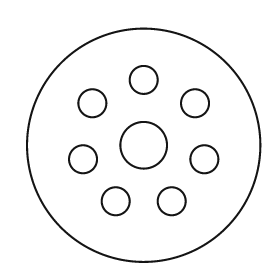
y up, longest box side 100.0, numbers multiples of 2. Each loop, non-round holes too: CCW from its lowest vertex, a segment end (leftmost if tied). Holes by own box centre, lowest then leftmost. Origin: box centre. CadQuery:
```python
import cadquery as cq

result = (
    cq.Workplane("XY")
    .moveTo(0.0, 0.0)
    .circle(50.0)
    .moveTo(-12.0, -24.0)
    .circle(6.0)
    .moveTo(12.0, -24.0)
    .circle(6.0)
    .moveTo(-26.0, -6.0)
    .circle(6.0)
    .moveTo(26.0, -6.0)
    .circle(6.0)
    .moveTo(0.0, 0.0)
    .circle(10.0)
    .moveTo(-22.0, 18.0)
    .circle(6.0)
    .moveTo(22.0, 18.0)
    .circle(6.0)
    .moveTo(0.0, 28.0)
    .circle(6.0)
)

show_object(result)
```